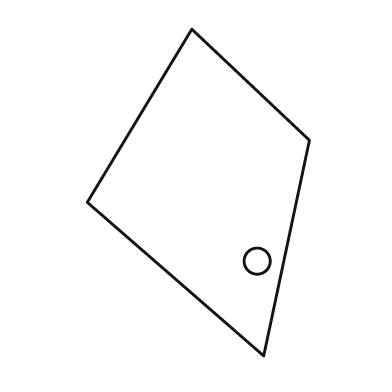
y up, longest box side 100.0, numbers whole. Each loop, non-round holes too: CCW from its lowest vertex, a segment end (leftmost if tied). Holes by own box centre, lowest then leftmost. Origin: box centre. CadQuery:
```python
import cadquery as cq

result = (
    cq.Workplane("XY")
    .moveTo(20.0, -50.0)
    .lineTo(34.0, 16.0)
    .lineTo(-2.0, 50.0)
    .lineTo(-34.0, -3.0)
    .close()
    .moveTo(18.0, -21.0)
    .circle(4.0)
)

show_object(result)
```